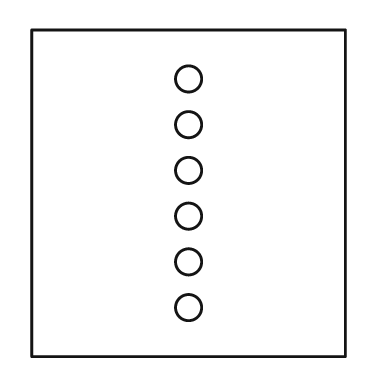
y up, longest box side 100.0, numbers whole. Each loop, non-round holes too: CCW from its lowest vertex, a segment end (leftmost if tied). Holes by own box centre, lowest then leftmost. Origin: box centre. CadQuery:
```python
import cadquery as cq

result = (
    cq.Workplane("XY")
    .moveTo(-48.0, -50.0)
    .lineTo(48.0, -50.0)
    .lineTo(48.0, 50.0)
    .lineTo(-48.0, 50.0)
    .close()
    .moveTo(0.0, -35.0)
    .circle(4.0)
    .moveTo(0.0, -21.0)
    .circle(4.0)
    .moveTo(0.0, -7.0)
    .circle(4.0)
    .moveTo(0.0, 7.0)
    .circle(4.0)
    .moveTo(0.0, 21.0)
    .circle(4.0)
    .moveTo(0.0, 35.0)
    .circle(4.0)
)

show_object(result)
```